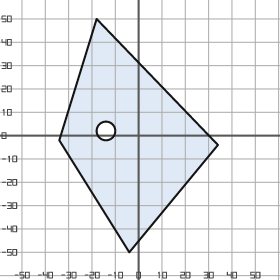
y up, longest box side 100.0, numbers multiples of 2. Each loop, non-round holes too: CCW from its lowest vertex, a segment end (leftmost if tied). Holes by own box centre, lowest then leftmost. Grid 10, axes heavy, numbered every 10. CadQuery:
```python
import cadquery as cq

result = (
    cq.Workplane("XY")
    .moveTo(-4.0, -50.0)
    .lineTo(34.0, -4.0)
    .lineTo(-18.0, 50.0)
    .lineTo(-34.0, -2.0)
    .close()
    .moveTo(-14.0, 2.0)
    .circle(4.0)
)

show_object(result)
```